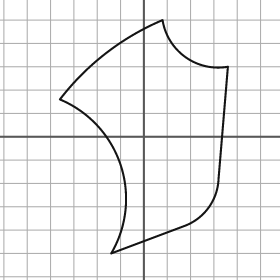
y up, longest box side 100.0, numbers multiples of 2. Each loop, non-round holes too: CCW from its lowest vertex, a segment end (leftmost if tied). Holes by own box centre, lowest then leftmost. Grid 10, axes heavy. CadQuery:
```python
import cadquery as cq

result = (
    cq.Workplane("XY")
    .moveTo(-14.0, -50.0)
    .lineTo(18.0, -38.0)
    .threePointArc((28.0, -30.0), (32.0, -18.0))
    .lineTo(36.0, 30.0)
    .threePointArc((18.0, 34.0), (8.0, 50.0))
    .threePointArc((-16.0, 36.0), (-36.0, 16.0))
    .threePointArc((-10.0, -12.0), (-14.0, -50.0))
    .close()
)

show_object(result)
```